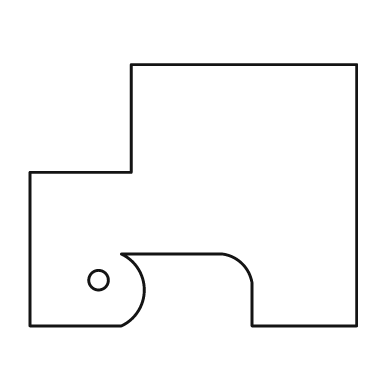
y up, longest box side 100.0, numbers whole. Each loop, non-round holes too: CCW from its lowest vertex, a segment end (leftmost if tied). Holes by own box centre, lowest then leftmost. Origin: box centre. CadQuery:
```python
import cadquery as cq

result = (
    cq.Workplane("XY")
    .moveTo(-50.0, -40.0)
    .lineTo(-22.0, -40.0)
    .threePointArc((-15.0, -29.0), (-22.0, -18.0))
    .lineTo(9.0, -18.0)
    .threePointArc((15.0, -21.0), (18.0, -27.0))
    .lineTo(18.0, -40.0)
    .lineTo(50.0, -40.0)
    .lineTo(50.0, 40.0)
    .lineTo(-19.0, 40.0)
    .lineTo(-19.0, 7.0)
    .lineTo(-50.0, 7.0)
    .close()
    .moveTo(-29.0, -26.0)
    .circle(3.0)
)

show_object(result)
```